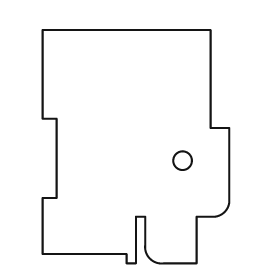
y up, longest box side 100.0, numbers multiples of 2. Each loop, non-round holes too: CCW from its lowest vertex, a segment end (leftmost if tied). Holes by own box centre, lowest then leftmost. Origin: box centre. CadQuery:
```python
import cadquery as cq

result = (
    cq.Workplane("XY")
    .moveTo(-4.0, -50.0)
    .lineTo(0.0, -50.0)
    .lineTo(0.0, -30.0)
    .lineTo(4.0, -30.0)
    .lineTo(4.0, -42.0)
    .threePointArc((6.0, -48.0), (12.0, -50.0))
    .lineTo(26.0, -50.0)
    .lineTo(26.0, -30.0)
    .lineTo(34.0, -30.0)
    .threePointArc((38.0, -28.0), (40.0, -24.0))
    .lineTo(40.0, 8.0)
    .lineTo(32.0, 8.0)
    .lineTo(32.0, 50.0)
    .lineTo(-40.0, 50.0)
    .lineTo(-40.0, 12.0)
    .lineTo(-34.0, 12.0)
    .lineTo(-34.0, -22.0)
    .lineTo(-40.0, -22.0)
    .lineTo(-40.0, -46.0)
    .lineTo(-4.0, -46.0)
    .close()
    .moveTo(20.0, -6.0)
    .circle(4.0)
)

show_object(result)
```